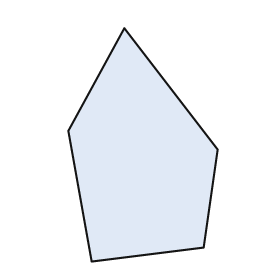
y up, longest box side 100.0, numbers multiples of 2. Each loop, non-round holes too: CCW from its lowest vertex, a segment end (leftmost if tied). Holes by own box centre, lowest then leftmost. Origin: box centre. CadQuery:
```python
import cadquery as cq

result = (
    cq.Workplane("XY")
    .moveTo(-22.0, -50.0)
    .lineTo(26.0, -44.0)
    .lineTo(32.0, -2.0)
    .lineTo(-8.0, 50.0)
    .lineTo(-32.0, 6.0)
    .close()
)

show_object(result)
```